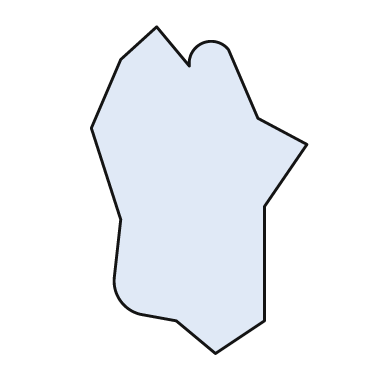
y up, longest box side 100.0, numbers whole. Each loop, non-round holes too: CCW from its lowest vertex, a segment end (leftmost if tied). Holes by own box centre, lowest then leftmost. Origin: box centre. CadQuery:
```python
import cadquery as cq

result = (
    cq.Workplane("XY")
    .moveTo(5.0, -50.0)
    .lineTo(20.0, -40.0)
    .lineTo(20.0, -5.0)
    .lineTo(33.0, 14.0)
    .lineTo(18.0, 22.0)
    .lineTo(9.0, 43.0)
    .threePointArc((1.0, 45.0), (-3.0, 38.0))
    .lineTo(-13.0, 50.0)
    .lineTo(-24.0, 40.0)
    .lineTo(-33.0, 19.0)
    .lineTo(-24.0, -9.0)
    .lineTo(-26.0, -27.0)
    .threePointArc((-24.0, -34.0), (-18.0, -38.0))
    .lineTo(-7.0, -40.0)
    .close()
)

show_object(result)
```